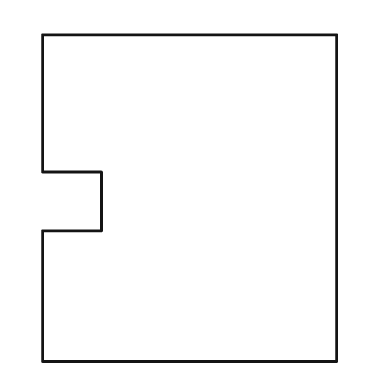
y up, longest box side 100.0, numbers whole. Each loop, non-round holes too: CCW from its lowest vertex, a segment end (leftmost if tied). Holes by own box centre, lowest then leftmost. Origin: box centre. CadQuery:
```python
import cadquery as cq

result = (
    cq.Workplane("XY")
    .moveTo(-45.0, -50.0)
    .lineTo(45.0, -50.0)
    .lineTo(45.0, 50.0)
    .lineTo(-45.0, 50.0)
    .lineTo(-45.0, 8.0)
    .lineTo(-27.0, 8.0)
    .lineTo(-27.0, -10.0)
    .lineTo(-45.0, -10.0)
    .close()
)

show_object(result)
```